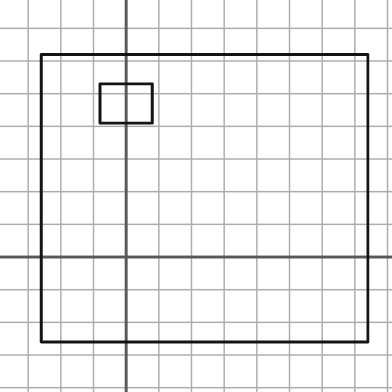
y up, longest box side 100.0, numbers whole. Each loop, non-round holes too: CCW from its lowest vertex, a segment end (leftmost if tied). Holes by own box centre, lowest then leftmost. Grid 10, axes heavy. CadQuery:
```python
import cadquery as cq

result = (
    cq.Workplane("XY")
    .moveTo(-26.0, -26.0)
    .lineTo(74.0, -26.0)
    .lineTo(74.0, 62.0)
    .lineTo(-26.0, 62.0)
    .close()
    .moveTo(-8.0, 41.0)
    .lineTo(8.0, 41.0)
    .lineTo(8.0, 53.0)
    .lineTo(-8.0, 53.0)
    .close()
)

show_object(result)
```